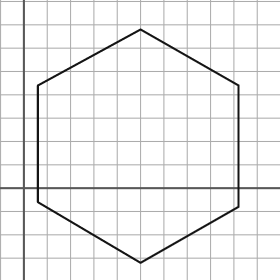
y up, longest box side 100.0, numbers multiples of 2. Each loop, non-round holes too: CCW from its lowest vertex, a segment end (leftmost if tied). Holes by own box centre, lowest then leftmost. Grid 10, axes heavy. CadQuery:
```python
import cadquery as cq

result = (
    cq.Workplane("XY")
    .moveTo(50.0, -32.0)
    .lineTo(92.0, -8.0)
    .lineTo(92.0, 44.0)
    .lineTo(50.0, 68.0)
    .lineTo(6.0, 44.0)
    .lineTo(6.0, -6.0)
    .close()
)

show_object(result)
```